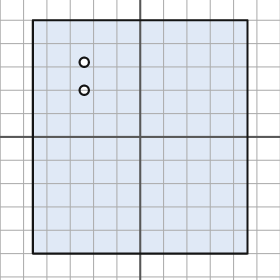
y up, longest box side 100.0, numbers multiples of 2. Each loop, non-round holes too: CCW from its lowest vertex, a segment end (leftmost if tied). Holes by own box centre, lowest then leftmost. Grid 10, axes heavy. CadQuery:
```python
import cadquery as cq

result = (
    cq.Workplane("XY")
    .moveTo(-46.0, -50.0)
    .lineTo(46.0, -50.0)
    .lineTo(46.0, 50.0)
    .lineTo(-46.0, 50.0)
    .close()
    .moveTo(-24.0, 20.0)
    .circle(2.0)
    .moveTo(-24.0, 32.0)
    .circle(2.0)
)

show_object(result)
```